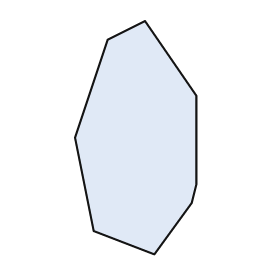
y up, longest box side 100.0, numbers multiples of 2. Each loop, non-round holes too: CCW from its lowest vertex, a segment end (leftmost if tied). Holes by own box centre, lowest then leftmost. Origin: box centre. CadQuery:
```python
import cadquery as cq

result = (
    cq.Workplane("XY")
    .moveTo(8.0, -50.0)
    .lineTo(24.0, -28.0)
    .lineTo(26.0, -20.0)
    .lineTo(26.0, 18.0)
    .lineTo(4.0, 50.0)
    .lineTo(-12.0, 42.0)
    .lineTo(-26.0, 0.0)
    .lineTo(-18.0, -40.0)
    .close()
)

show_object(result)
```